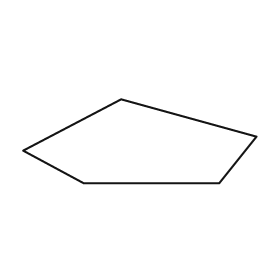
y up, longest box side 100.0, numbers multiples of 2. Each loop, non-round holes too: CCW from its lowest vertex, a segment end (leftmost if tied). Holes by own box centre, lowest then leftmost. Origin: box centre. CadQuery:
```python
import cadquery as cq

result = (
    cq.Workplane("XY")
    .moveTo(-24.0, -18.0)
    .lineTo(34.0, -18.0)
    .lineTo(50.0, 2.0)
    .lineTo(-8.0, 18.0)
    .lineTo(-50.0, -4.0)
    .close()
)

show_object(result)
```